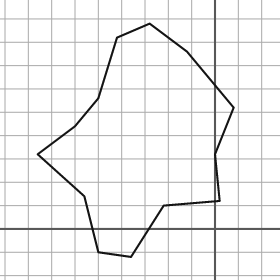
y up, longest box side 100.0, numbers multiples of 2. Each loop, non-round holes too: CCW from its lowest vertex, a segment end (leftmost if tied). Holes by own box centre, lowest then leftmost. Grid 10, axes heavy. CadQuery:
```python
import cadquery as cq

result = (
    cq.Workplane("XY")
    .moveTo(-36.0, -12.0)
    .lineTo(-22.0, 10.0)
    .lineTo(2.0, 12.0)
    .lineTo(0.0, 32.0)
    .lineTo(8.0, 52.0)
    .lineTo(-12.0, 76.0)
    .lineTo(-28.0, 88.0)
    .lineTo(-42.0, 82.0)
    .lineTo(-50.0, 56.0)
    .lineTo(-60.0, 44.0)
    .lineTo(-76.0, 32.0)
    .lineTo(-56.0, 14.0)
    .lineTo(-50.0, -10.0)
    .close()
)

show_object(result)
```